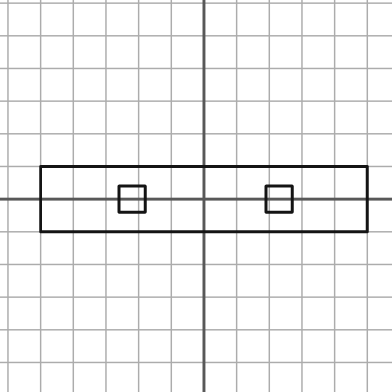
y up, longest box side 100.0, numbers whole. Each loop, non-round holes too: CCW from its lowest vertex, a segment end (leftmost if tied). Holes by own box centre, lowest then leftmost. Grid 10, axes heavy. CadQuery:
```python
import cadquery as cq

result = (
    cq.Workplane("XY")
    .moveTo(-50.0, -10.0)
    .lineTo(50.0, -10.0)
    .lineTo(50.0, 10.0)
    .lineTo(-50.0, 10.0)
    .close()
    .moveTo(-26.0, -4.0)
    .lineTo(-18.0, -4.0)
    .lineTo(-18.0, 4.0)
    .lineTo(-26.0, 4.0)
    .close()
    .moveTo(19.0, -4.0)
    .lineTo(27.0, -4.0)
    .lineTo(27.0, 4.0)
    .lineTo(19.0, 4.0)
    .close()
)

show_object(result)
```